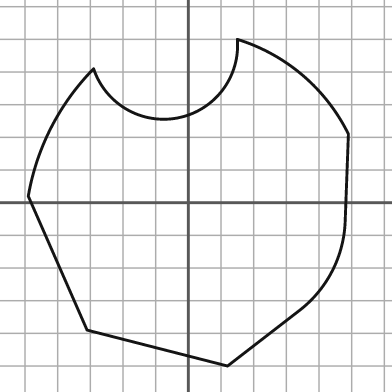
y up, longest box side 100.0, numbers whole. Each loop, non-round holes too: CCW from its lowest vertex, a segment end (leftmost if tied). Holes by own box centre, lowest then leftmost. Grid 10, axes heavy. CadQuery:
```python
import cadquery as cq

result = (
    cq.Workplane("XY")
    .moveTo(12.0, -50.0)
    .lineTo(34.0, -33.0)
    .threePointArc((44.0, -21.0), (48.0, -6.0))
    .lineTo(49.0, 21.0)
    .threePointArc((35.0, 39.0), (15.0, 50.0))
    .threePointArc((-3.0, 26.0), (-29.0, 41.0))
    .threePointArc((-42.0, 23.0), (-49.0, 2.0))
    .lineTo(-31.0, -39.0)
    .close()
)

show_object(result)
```